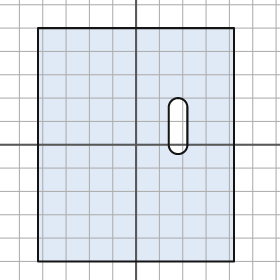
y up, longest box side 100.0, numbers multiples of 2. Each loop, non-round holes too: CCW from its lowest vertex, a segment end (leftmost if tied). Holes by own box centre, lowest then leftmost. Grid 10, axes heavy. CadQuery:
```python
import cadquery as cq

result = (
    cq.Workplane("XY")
    .moveTo(-42.0, -50.0)
    .lineTo(42.0, -50.0)
    .lineTo(42.0, 50.0)
    .lineTo(-42.0, 50.0)
    .close()
    .moveTo(14.0, 0.0)
    .threePointArc((18.0, -4.0), (22.0, 0.0))
    .lineTo(22.0, 16.0)
    .threePointArc((18.0, 20.0), (14.0, 16.0))
    .close()
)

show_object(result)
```